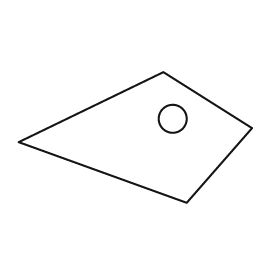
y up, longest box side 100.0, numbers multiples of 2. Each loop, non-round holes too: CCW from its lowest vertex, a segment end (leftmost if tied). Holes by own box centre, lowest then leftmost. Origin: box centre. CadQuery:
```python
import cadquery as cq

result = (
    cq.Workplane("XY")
    .moveTo(22.0, -28.0)
    .lineTo(50.0, 4.0)
    .lineTo(12.0, 28.0)
    .lineTo(-50.0, -2.0)
    .close()
    .moveTo(16.0, 8.0)
    .circle(6.0)
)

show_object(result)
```